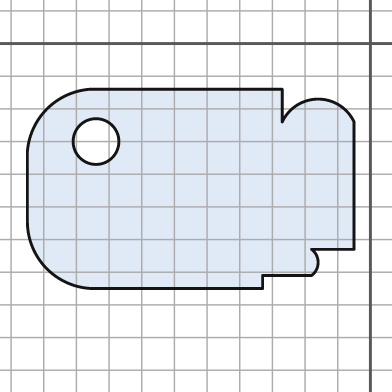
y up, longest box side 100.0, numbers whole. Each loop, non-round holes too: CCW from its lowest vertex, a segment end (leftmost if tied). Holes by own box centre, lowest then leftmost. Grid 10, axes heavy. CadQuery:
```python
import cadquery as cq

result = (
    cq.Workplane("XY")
    .moveTo(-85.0, -75.0)
    .lineTo(-33.0, -75.0)
    .lineTo(-33.0, -71.0)
    .lineTo(-18.0, -71.0)
    .threePointArc((-16.0, -67.0), (-18.0, -63.0))
    .lineTo(-5.0, -63.0)
    .lineTo(-5.0, -24.0)
    .threePointArc((-16.0, -17.0), (-27.0, -24.0))
    .lineTo(-27.0, -14.0)
    .lineTo(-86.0, -14.0)
    .threePointArc((-99.0, -20.0), (-105.0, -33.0))
    .lineTo(-105.0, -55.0)
    .threePointArc((-99.0, -69.0), (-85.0, -75.0))
    .close()
    .moveTo(-84.0, -30.0)
    .circle(7.0)
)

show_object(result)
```